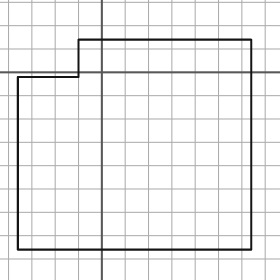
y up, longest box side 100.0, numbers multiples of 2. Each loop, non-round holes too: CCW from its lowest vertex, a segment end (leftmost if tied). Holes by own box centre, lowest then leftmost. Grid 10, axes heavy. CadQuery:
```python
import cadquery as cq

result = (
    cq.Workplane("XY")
    .moveTo(-36.0, -76.0)
    .lineTo(64.0, -76.0)
    .lineTo(64.0, 14.0)
    .lineTo(-10.0, 14.0)
    .lineTo(-10.0, -2.0)
    .lineTo(-36.0, -2.0)
    .close()
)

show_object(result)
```